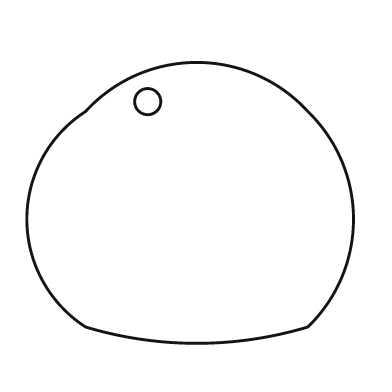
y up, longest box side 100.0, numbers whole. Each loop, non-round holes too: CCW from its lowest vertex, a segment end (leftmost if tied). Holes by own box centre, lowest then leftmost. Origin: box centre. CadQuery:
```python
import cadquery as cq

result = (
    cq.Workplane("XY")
    .moveTo(-32.0, -38.0)
    .threePointArc((2.0, -43.0), (36.0, -38.0))
    .threePointArc((50.0, -5.0), (36.0, 28.0))
    .threePointArc((2.0, 43.0), (-32.0, 28.0))
    .threePointArc((-50.0, -5.0), (-32.0, -38.0))
    .close()
    .moveTo(-13.0, 31.0)
    .circle(4.0)
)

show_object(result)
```